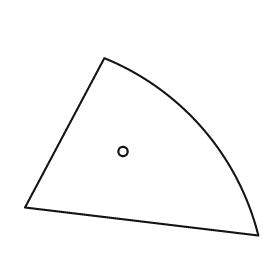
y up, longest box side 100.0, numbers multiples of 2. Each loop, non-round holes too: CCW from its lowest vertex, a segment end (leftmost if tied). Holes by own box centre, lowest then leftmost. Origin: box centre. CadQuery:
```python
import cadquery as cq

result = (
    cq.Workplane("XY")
    .moveTo(50.0, -38.0)
    .threePointArc((26.0, 8.0), (-16.0, 38.0))
    .lineTo(-50.0, -26.0)
    .close()
    .moveTo(-8.0, -2.0)
    .circle(2.0)
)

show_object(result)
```